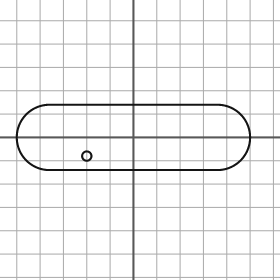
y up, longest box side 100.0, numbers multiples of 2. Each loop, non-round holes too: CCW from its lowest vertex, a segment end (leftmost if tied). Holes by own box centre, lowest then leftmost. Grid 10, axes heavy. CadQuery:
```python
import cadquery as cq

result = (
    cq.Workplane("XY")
    .moveTo(-36.0, -14.0)
    .lineTo(36.0, -14.0)
    .threePointArc((50.0, 0.0), (36.0, 14.0))
    .lineTo(-36.0, 14.0)
    .threePointArc((-50.0, 0.0), (-36.0, -14.0))
    .close()
    .moveTo(-20.0, -8.0)
    .circle(2.0)
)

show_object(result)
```